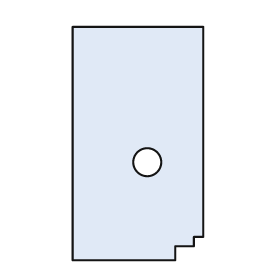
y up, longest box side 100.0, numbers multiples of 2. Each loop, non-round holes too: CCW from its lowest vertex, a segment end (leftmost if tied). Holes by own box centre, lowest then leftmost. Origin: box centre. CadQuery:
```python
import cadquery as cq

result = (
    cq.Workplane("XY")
    .moveTo(-28.0, -50.0)
    .lineTo(16.0, -50.0)
    .lineTo(16.0, -44.0)
    .lineTo(24.0, -44.0)
    .lineTo(24.0, -40.0)
    .lineTo(28.0, -40.0)
    .lineTo(28.0, 50.0)
    .lineTo(-28.0, 50.0)
    .close()
    .moveTo(4.0, -8.0)
    .circle(6.0)
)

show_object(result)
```